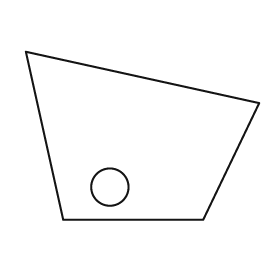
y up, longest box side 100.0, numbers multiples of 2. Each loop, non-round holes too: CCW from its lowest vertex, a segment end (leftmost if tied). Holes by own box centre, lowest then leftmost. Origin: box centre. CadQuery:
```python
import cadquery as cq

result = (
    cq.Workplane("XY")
    .moveTo(-34.0, -36.0)
    .lineTo(26.0, -36.0)
    .lineTo(50.0, 14.0)
    .lineTo(-50.0, 36.0)
    .close()
    .moveTo(-14.0, -22.0)
    .circle(8.0)
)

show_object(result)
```